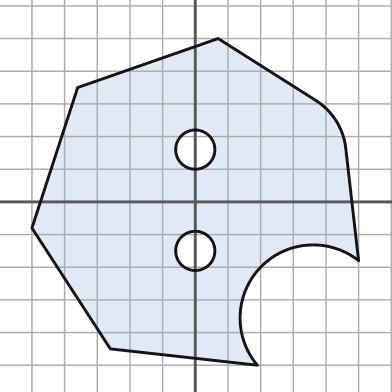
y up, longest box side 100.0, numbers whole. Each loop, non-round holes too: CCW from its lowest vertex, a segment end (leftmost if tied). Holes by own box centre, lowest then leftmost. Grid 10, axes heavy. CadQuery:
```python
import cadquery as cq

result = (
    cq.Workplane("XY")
    .moveTo(19.0, -50.0)
    .threePointArc((20.0, -20.0), (50.0, -18.0))
    .lineTo(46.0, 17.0)
    .threePointArc((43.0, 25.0), (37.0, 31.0))
    .lineTo(7.0, 50.0)
    .lineTo(-36.0, 35.0)
    .lineTo(-50.0, -8.0)
    .lineTo(-26.0, -45.0)
    .close()
    .moveTo(0.0, -15.0)
    .circle(6.0)
    .moveTo(0.0, 16.0)
    .circle(6.0)
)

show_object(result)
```